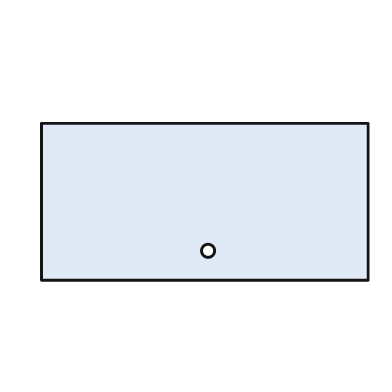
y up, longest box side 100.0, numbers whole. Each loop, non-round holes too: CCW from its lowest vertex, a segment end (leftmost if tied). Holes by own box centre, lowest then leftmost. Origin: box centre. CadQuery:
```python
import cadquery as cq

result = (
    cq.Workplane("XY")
    .moveTo(-50.0, -24.0)
    .lineTo(50.0, -24.0)
    .lineTo(50.0, 24.0)
    .lineTo(-50.0, 24.0)
    .close()
    .moveTo(1.0, -15.0)
    .circle(2.0)
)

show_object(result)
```